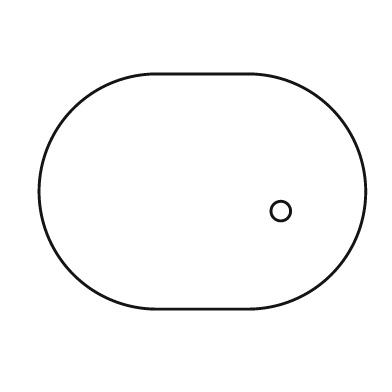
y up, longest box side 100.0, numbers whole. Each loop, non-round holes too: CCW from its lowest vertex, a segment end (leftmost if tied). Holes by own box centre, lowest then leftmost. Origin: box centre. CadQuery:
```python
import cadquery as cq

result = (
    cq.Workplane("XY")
    .moveTo(-14.0, -36.0)
    .lineTo(14.0, -36.0)
    .threePointArc((50.0, 0.0), (14.0, 36.0))
    .lineTo(-14.0, 36.0)
    .threePointArc((-50.0, 0.0), (-14.0, -36.0))
    .close()
    .moveTo(24.0, -6.0)
    .circle(3.0)
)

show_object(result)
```